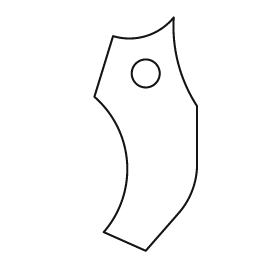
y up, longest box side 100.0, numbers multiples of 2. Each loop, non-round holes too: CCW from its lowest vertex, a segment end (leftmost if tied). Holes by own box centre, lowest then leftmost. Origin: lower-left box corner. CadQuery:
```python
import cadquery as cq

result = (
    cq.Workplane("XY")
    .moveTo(22.0, 0.0)
    .lineTo(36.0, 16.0)
    .threePointArc((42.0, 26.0), (44.0, 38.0))
    .lineTo(44.0, 62.0)
    .threePointArc((36.0, 80.0), (34.0, 100.0))
    .threePointArc((22.0, 92.0), (8.0, 92.0))
    .lineTo(0.0, 66.0)
    .threePointArc((14.0, 38.0), (4.0, 8.0))
    .close()
    .moveTo(22.0, 76.0)
    .circle(6.0)
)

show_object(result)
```